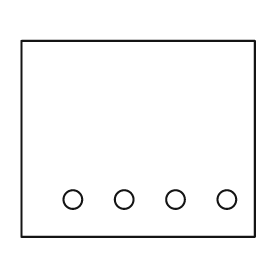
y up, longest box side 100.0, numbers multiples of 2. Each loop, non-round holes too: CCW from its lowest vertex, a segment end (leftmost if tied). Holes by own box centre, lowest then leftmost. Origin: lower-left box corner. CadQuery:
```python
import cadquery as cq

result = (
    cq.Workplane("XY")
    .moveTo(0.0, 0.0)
    .lineTo(100.0, 0.0)
    .lineTo(100.0, 84.0)
    .lineTo(0.0, 84.0)
    .close()
    .moveTo(22.0, 16.0)
    .circle(4.0)
    .moveTo(44.0, 16.0)
    .circle(4.0)
    .moveTo(66.0, 16.0)
    .circle(4.0)
    .moveTo(88.0, 16.0)
    .circle(4.0)
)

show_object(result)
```